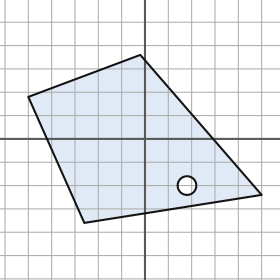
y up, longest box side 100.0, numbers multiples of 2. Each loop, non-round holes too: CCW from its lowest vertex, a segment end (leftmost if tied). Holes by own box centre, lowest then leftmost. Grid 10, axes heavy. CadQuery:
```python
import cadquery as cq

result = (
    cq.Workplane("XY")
    .moveTo(-26.0, -36.0)
    .lineTo(50.0, -24.0)
    .lineTo(-2.0, 36.0)
    .lineTo(-50.0, 18.0)
    .close()
    .moveTo(18.0, -20.0)
    .circle(4.0)
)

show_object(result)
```